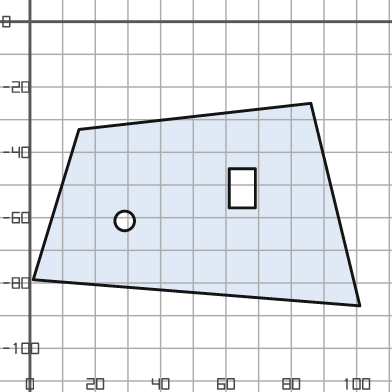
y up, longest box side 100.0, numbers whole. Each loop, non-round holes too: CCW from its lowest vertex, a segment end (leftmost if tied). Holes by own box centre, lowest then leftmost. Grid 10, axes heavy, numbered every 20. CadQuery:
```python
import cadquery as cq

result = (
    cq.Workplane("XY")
    .moveTo(101.0, -87.0)
    .lineTo(86.0, -25.0)
    .lineTo(15.0, -33.0)
    .lineTo(1.0, -79.0)
    .close()
    .moveTo(29.0, -61.0)
    .circle(3.0)
    .moveTo(61.0, -57.0)
    .lineTo(69.0, -57.0)
    .lineTo(69.0, -45.0)
    .lineTo(61.0, -45.0)
    .close()
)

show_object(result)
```